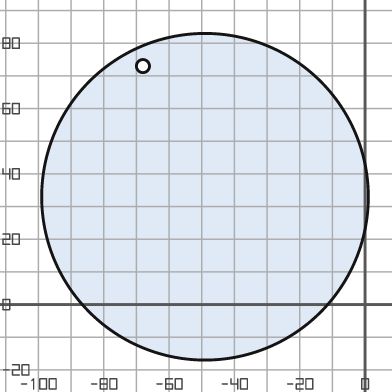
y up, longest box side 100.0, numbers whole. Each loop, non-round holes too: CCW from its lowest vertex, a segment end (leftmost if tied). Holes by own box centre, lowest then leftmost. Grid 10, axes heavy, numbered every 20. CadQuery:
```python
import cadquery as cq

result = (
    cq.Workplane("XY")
    .moveTo(-49.0, 33.0)
    .circle(50.0)
    .moveTo(-68.0, 73.0)
    .circle(2.0)
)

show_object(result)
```